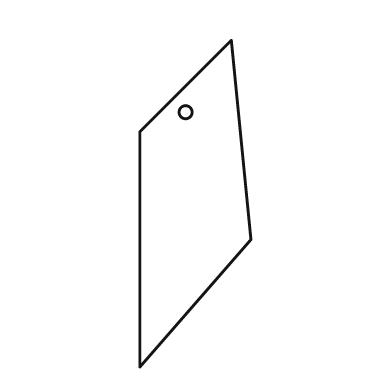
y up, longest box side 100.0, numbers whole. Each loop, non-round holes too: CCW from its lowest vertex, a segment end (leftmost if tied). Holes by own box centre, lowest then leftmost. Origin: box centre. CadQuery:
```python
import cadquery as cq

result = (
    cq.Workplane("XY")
    .moveTo(-17.0, -50.0)
    .lineTo(17.0, -11.0)
    .lineTo(11.0, 50.0)
    .lineTo(-17.0, 22.0)
    .close()
    .moveTo(-3.0, 28.0)
    .circle(2.0)
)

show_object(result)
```